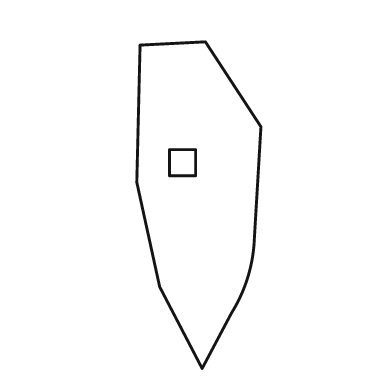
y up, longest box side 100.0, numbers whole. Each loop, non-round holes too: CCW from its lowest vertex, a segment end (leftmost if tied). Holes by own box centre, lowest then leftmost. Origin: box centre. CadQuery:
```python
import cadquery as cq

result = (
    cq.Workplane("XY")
    .moveTo(1.0, -50.0)
    .lineTo(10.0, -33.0)
    .threePointArc((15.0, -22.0), (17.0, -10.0))
    .lineTo(19.0, 24.0)
    .lineTo(2.0, 50.0)
    .lineTo(-18.0, 49.0)
    .lineTo(-19.0, 7.0)
    .lineTo(-12.0, -25.0)
    .close()
    .moveTo(-9.0, 9.0)
    .lineTo(-1.0, 9.0)
    .lineTo(-1.0, 17.0)
    .lineTo(-9.0, 17.0)
    .close()
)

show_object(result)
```